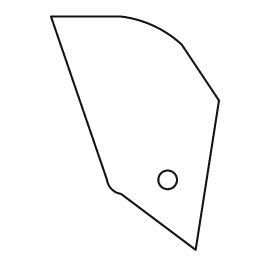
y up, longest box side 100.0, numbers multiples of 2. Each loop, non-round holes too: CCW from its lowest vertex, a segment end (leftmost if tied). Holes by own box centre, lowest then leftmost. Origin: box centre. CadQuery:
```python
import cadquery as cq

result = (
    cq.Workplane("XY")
    .moveTo(26.0, -50.0)
    .lineTo(36.0, 14.0)
    .lineTo(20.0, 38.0)
    .threePointArc((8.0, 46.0), (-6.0, 50.0))
    .lineTo(-36.0, 50.0)
    .lineTo(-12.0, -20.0)
    .threePointArc((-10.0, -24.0), (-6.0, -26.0))
    .close()
    .moveTo(14.0, -20.0)
    .circle(4.0)
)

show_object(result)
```